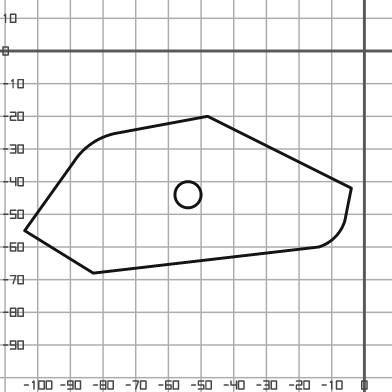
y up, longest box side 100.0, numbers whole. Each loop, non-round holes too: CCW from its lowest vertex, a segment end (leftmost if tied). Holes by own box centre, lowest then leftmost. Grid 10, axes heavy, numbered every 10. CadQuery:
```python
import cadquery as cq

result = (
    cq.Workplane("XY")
    .moveTo(-83.0, -68.0)
    .lineTo(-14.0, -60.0)
    .threePointArc((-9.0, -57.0), (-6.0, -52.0))
    .lineTo(-4.0, -42.0)
    .lineTo(-48.0, -20.0)
    .lineTo(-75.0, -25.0)
    .threePointArc((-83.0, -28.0), (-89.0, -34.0))
    .lineTo(-104.0, -55.0)
    .close()
    .moveTo(-54.0, -44.0)
    .circle(4.0)
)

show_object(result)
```